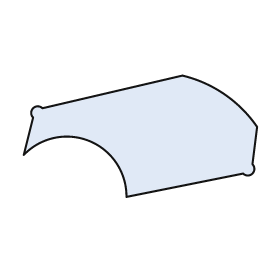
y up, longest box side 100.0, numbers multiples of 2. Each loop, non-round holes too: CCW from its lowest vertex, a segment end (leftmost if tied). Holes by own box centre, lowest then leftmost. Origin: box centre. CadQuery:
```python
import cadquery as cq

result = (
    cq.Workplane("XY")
    .moveTo(-6.0, -26.0)
    .lineTo(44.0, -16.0)
    .threePointArc((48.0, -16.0), (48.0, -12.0))
    .lineTo(50.0, 4.0)
    .threePointArc((36.0, 18.0), (18.0, 26.0))
    .lineTo(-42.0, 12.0)
    .threePointArc((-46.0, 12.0), (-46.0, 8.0))
    .lineTo(-50.0, -8.0)
    .threePointArc((-22.0, -2.0), (-6.0, -26.0))
    .close()
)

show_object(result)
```